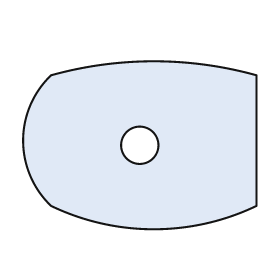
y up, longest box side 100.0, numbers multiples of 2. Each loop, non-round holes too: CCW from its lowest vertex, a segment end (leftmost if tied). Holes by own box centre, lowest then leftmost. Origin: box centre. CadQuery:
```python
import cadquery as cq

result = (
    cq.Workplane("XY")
    .moveTo(-38.0, -26.0)
    .threePointArc((6.0, -36.0), (50.0, -26.0))
    .lineTo(50.0, 30.0)
    .threePointArc((6.0, 36.0), (-38.0, 30.0))
    .threePointArc((-50.0, 2.0), (-38.0, -26.0))
    .close()
    .moveTo(0.0, 0.0)
    .circle(8.0)
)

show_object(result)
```